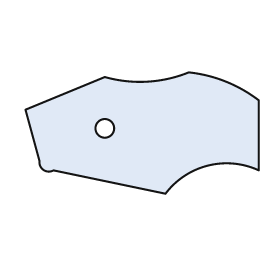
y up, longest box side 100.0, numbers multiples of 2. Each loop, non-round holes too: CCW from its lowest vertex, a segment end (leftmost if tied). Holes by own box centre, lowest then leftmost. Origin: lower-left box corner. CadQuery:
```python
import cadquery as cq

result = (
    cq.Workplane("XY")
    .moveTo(60.0, 0.0)
    .threePointArc((78.0, 12.0), (100.0, 10.0))
    .lineTo(100.0, 40.0)
    .threePointArc((86.0, 48.0), (70.0, 52.0))
    .threePointArc((52.0, 48.0), (34.0, 50.0))
    .lineTo(0.0, 36.0)
    .lineTo(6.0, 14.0)
    .threePointArc((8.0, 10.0), (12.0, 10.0))
    .close()
    .moveTo(34.0, 28.0)
    .circle(4.0)
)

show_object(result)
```